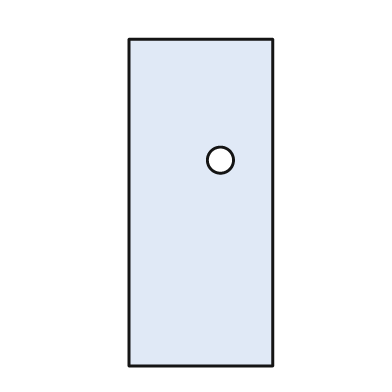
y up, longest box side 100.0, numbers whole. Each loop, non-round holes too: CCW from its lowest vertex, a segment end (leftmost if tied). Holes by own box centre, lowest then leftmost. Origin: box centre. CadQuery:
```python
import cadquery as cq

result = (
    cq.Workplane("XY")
    .moveTo(-22.0, -50.0)
    .lineTo(22.0, -50.0)
    .lineTo(22.0, 50.0)
    .lineTo(-22.0, 50.0)
    .close()
    .moveTo(6.0, 13.0)
    .circle(4.0)
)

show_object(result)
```